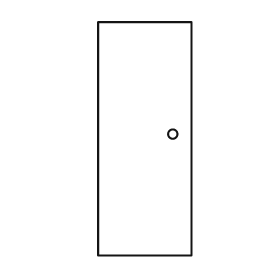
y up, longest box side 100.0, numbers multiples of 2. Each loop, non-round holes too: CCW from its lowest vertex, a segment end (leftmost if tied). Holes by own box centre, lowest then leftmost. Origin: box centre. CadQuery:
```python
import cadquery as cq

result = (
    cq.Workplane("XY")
    .moveTo(-20.0, -50.0)
    .lineTo(20.0, -50.0)
    .lineTo(20.0, 50.0)
    .lineTo(-20.0, 50.0)
    .close()
    .moveTo(12.0, 2.0)
    .circle(2.0)
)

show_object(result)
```